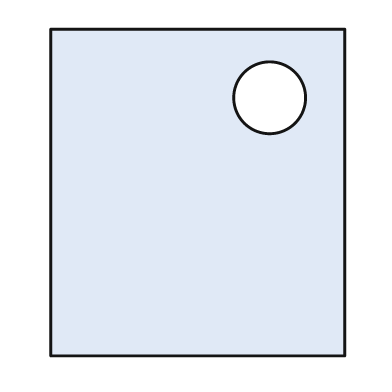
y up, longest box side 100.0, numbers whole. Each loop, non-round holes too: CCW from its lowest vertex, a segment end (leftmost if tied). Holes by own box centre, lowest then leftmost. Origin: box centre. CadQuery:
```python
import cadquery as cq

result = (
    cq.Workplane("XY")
    .moveTo(-45.0, -50.0)
    .lineTo(45.0, -50.0)
    .lineTo(45.0, 50.0)
    .lineTo(-45.0, 50.0)
    .close()
    .moveTo(22.0, 29.0)
    .circle(11.0)
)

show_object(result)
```